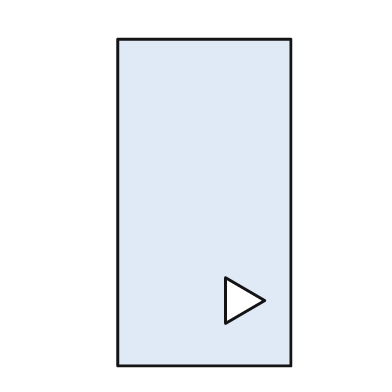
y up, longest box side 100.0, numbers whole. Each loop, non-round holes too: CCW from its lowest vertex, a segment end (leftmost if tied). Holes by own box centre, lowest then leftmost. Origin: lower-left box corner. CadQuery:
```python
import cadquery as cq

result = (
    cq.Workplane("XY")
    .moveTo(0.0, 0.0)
    .lineTo(53.0, 0.0)
    .lineTo(53.0, 100.0)
    .lineTo(0.0, 100.0)
    .close()
    .moveTo(33.0, 13.0)
    .lineTo(45.0, 20.0)
    .lineTo(33.0, 27.0)
    .close()
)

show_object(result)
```